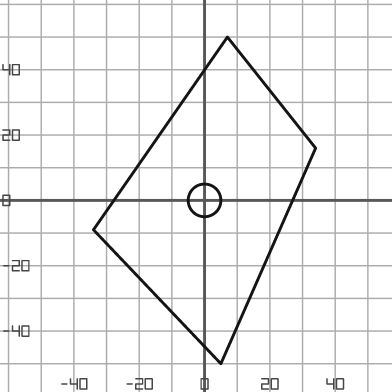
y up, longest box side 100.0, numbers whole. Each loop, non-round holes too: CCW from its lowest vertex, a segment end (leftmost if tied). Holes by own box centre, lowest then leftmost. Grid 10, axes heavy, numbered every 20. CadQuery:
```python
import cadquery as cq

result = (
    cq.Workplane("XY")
    .moveTo(5.0, -50.0)
    .lineTo(34.0, 16.0)
    .lineTo(7.0, 50.0)
    .lineTo(-34.0, -9.0)
    .close()
    .moveTo(0.0, 0.0)
    .circle(5.0)
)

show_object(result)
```